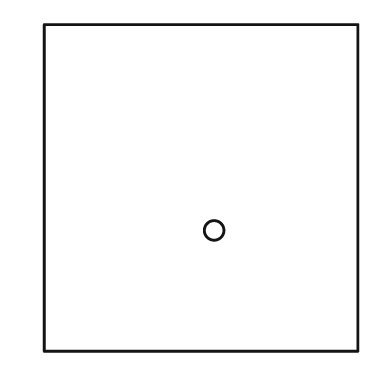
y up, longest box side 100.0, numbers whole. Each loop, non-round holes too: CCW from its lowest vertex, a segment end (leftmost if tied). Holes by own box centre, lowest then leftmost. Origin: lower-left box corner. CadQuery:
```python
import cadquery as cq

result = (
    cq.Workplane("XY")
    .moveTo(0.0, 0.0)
    .lineTo(96.0, 0.0)
    .lineTo(96.0, 100.0)
    .lineTo(0.0, 100.0)
    .close()
    .moveTo(52.0, 37.0)
    .circle(3.0)
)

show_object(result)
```